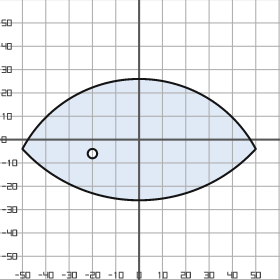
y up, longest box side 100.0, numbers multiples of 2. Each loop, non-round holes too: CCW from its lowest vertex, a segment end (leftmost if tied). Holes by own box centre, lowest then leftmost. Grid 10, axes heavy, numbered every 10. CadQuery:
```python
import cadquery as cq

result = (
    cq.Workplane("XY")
    .moveTo(-50.0, -4.0)
    .threePointArc((0.0, -26.0), (50.0, -4.0))
    .threePointArc((0.0, 26.0), (-50.0, -4.0))
    .close()
    .moveTo(-20.0, -6.0)
    .circle(2.0)
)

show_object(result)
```